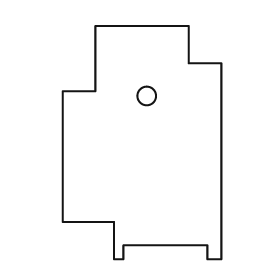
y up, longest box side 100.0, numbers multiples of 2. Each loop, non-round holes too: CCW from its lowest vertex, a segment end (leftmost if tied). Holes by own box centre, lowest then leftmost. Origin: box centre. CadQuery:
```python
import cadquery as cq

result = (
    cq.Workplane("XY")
    .moveTo(-12.0, -50.0)
    .lineTo(-8.0, -50.0)
    .lineTo(-8.0, -44.0)
    .lineTo(28.0, -44.0)
    .lineTo(28.0, -50.0)
    .lineTo(34.0, -50.0)
    .lineTo(34.0, 34.0)
    .lineTo(20.0, 34.0)
    .lineTo(20.0, 50.0)
    .lineTo(-20.0, 50.0)
    .lineTo(-20.0, 22.0)
    .lineTo(-34.0, 22.0)
    .lineTo(-34.0, -34.0)
    .lineTo(-12.0, -34.0)
    .close()
    .moveTo(2.0, 20.0)
    .circle(4.0)
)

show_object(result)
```